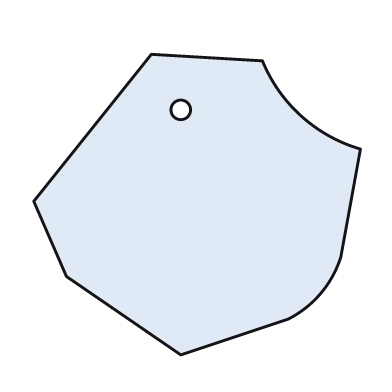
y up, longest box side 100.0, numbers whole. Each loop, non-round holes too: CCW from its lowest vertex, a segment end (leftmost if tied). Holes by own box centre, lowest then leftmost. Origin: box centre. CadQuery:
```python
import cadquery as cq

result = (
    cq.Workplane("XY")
    .moveTo(-5.0, -46.0)
    .lineTo(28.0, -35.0)
    .threePointArc((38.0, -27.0), (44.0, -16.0))
    .lineTo(50.0, 17.0)
    .threePointArc((32.0, 27.0), (20.0, 44.0))
    .lineTo(-14.0, 46.0)
    .lineTo(-50.0, 1.0)
    .lineTo(-40.0, -22.0)
    .close()
    .moveTo(-5.0, 29.0)
    .circle(3.0)
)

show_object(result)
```